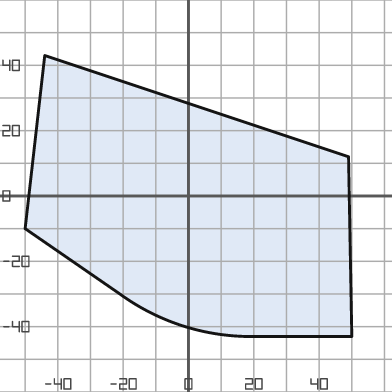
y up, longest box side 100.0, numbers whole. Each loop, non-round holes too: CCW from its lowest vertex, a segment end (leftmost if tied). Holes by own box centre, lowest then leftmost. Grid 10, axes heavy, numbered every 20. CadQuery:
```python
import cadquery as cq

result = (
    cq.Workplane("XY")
    .moveTo(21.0, -43.0)
    .lineTo(50.0, -43.0)
    .lineTo(49.0, 12.0)
    .lineTo(-44.0, 43.0)
    .lineTo(-50.0, -10.0)
    .lineTo(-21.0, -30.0)
    .threePointArc((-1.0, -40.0), (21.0, -43.0))
    .close()
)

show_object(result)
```